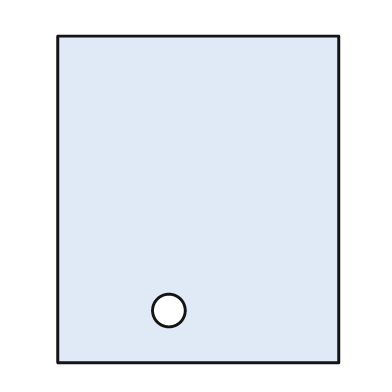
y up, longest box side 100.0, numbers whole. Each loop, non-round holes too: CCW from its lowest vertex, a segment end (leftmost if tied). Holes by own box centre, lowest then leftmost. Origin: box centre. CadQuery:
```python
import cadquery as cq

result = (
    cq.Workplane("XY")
    .moveTo(-43.0, -50.0)
    .lineTo(43.0, -50.0)
    .lineTo(43.0, 50.0)
    .lineTo(-43.0, 50.0)
    .close()
    .moveTo(-9.0, -34.0)
    .circle(5.0)
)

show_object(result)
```